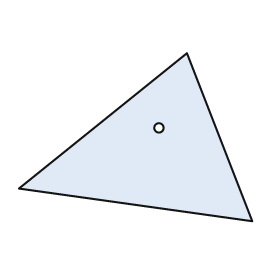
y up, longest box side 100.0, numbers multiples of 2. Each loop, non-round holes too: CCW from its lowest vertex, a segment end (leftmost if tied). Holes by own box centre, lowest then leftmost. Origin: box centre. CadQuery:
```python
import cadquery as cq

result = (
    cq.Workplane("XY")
    .moveTo(50.0, -36.0)
    .lineTo(22.0, 36.0)
    .lineTo(-50.0, -22.0)
    .close()
    .moveTo(10.0, 4.0)
    .circle(2.0)
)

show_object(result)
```